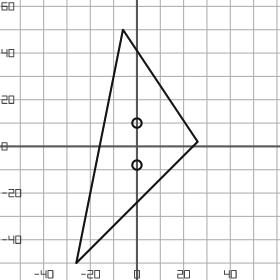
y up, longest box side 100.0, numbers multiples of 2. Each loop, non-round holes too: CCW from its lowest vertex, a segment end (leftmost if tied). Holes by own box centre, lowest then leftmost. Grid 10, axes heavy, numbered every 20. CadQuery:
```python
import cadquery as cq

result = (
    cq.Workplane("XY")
    .moveTo(-26.0, -50.0)
    .lineTo(26.0, 2.0)
    .lineTo(-6.0, 50.0)
    .close()
    .moveTo(0.0, -8.0)
    .circle(2.0)
    .moveTo(0.0, 10.0)
    .circle(2.0)
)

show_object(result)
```